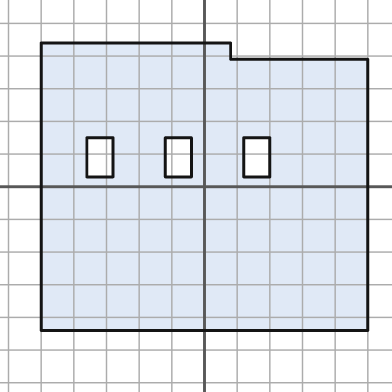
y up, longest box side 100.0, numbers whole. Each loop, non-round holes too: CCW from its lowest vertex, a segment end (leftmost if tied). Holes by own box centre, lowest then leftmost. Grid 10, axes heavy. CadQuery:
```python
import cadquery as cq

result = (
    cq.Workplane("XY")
    .moveTo(-50.0, -44.0)
    .lineTo(50.0, -44.0)
    .lineTo(50.0, 39.0)
    .lineTo(8.0, 39.0)
    .lineTo(8.0, 44.0)
    .lineTo(-50.0, 44.0)
    .close()
    .moveTo(-36.0, 3.0)
    .lineTo(-28.0, 3.0)
    .lineTo(-28.0, 15.0)
    .lineTo(-36.0, 15.0)
    .close()
    .moveTo(-12.0, 3.0)
    .lineTo(-4.0, 3.0)
    .lineTo(-4.0, 15.0)
    .lineTo(-12.0, 15.0)
    .close()
    .moveTo(12.0, 3.0)
    .lineTo(20.0, 3.0)
    .lineTo(20.0, 15.0)
    .lineTo(12.0, 15.0)
    .close()
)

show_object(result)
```